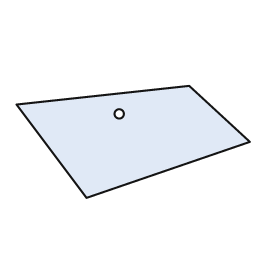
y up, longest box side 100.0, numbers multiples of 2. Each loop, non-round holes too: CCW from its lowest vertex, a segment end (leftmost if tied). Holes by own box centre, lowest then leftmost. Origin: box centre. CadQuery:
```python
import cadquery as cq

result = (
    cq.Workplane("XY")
    .moveTo(-20.0, -24.0)
    .lineTo(50.0, 0.0)
    .lineTo(24.0, 24.0)
    .lineTo(-50.0, 16.0)
    .close()
    .moveTo(-6.0, 12.0)
    .circle(2.0)
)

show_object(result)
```